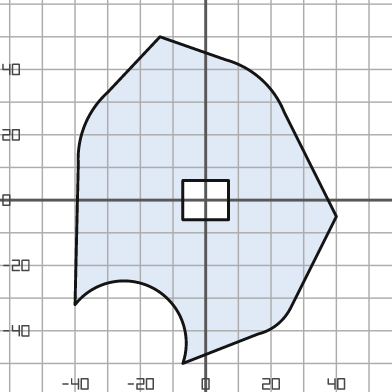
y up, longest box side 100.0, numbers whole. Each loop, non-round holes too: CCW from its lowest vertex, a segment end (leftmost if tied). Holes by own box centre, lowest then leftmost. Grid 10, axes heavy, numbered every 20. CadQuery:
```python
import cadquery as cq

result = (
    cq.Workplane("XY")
    .moveTo(-7.0, -50.0)
    .lineTo(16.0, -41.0)
    .threePointArc((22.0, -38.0), (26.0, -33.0))
    .lineTo(40.0, -5.0)
    .lineTo(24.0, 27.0)
    .threePointArc((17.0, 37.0), (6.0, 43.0))
    .lineTo(-14.0, 50.0)
    .lineTo(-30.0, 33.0)
    .threePointArc((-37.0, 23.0), (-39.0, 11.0))
    .lineTo(-40.0, -32.0)
    .threePointArc((-16.0, -27.0), (-7.0, -50.0))
    .close()
    .moveTo(-7.0, -6.0)
    .lineTo(7.0, -6.0)
    .lineTo(7.0, 6.0)
    .lineTo(-7.0, 6.0)
    .close()
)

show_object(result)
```